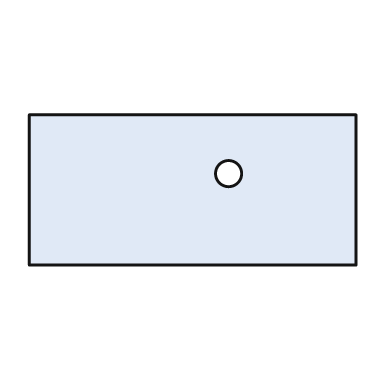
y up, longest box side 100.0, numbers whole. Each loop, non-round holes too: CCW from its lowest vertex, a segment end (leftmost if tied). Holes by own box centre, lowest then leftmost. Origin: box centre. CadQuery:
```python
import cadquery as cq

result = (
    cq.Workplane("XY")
    .moveTo(-50.0, -23.0)
    .lineTo(50.0, -23.0)
    .lineTo(50.0, 23.0)
    .lineTo(-50.0, 23.0)
    .close()
    .moveTo(11.0, 5.0)
    .circle(4.0)
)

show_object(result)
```